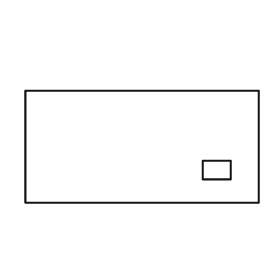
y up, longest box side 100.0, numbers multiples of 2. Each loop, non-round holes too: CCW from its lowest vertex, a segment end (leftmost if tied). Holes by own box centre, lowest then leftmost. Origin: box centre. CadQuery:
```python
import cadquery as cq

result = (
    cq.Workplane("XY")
    .moveTo(-50.0, -24.0)
    .lineTo(50.0, -24.0)
    .lineTo(50.0, 24.0)
    .lineTo(-50.0, 24.0)
    .close()
    .moveTo(26.0, -14.0)
    .lineTo(38.0, -14.0)
    .lineTo(38.0, -6.0)
    .lineTo(26.0, -6.0)
    .close()
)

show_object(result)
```